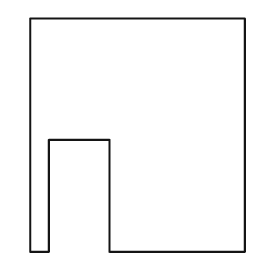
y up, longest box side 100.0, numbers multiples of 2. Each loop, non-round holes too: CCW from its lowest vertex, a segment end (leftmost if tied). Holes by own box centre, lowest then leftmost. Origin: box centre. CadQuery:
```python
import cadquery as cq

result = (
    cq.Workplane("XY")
    .moveTo(-46.0, -50.0)
    .lineTo(-38.0, -50.0)
    .lineTo(-38.0, -2.0)
    .lineTo(-12.0, -2.0)
    .lineTo(-12.0, -50.0)
    .lineTo(46.0, -50.0)
    .lineTo(46.0, 50.0)
    .lineTo(-46.0, 50.0)
    .close()
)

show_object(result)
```